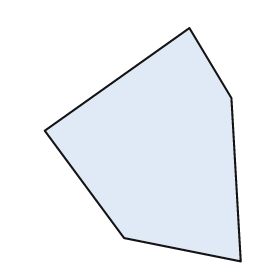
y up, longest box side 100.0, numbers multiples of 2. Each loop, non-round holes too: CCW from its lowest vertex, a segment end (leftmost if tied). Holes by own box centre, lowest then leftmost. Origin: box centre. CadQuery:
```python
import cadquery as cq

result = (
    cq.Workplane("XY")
    .moveTo(42.0, -50.0)
    .lineTo(38.0, 20.0)
    .lineTo(20.0, 50.0)
    .lineTo(-42.0, 6.0)
    .lineTo(-8.0, -40.0)
    .close()
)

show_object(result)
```